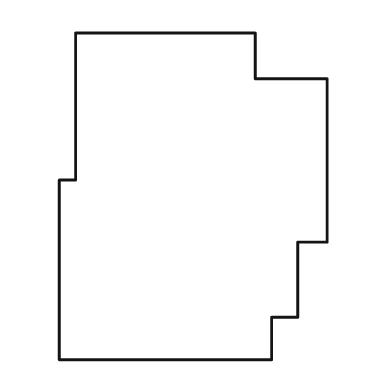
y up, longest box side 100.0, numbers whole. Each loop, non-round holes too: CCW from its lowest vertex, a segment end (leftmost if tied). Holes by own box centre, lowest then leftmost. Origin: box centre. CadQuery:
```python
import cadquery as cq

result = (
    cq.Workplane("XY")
    .moveTo(-41.0, -50.0)
    .lineTo(24.0, -50.0)
    .lineTo(24.0, -37.0)
    .lineTo(32.0, -37.0)
    .lineTo(32.0, -14.0)
    .lineTo(41.0, -14.0)
    .lineTo(41.0, 36.0)
    .lineTo(19.0, 36.0)
    .lineTo(19.0, 50.0)
    .lineTo(-36.0, 50.0)
    .lineTo(-36.0, 5.0)
    .lineTo(-41.0, 5.0)
    .close()
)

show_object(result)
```